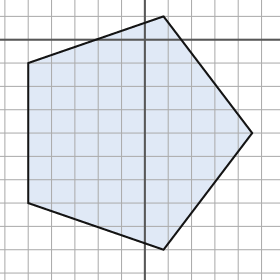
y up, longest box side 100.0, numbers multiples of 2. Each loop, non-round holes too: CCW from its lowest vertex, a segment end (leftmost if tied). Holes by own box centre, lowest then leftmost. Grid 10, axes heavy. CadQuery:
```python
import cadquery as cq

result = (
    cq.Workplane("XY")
    .moveTo(8.0, -90.0)
    .lineTo(46.0, -40.0)
    .lineTo(8.0, 10.0)
    .lineTo(-50.0, -10.0)
    .lineTo(-50.0, -70.0)
    .close()
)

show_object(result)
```